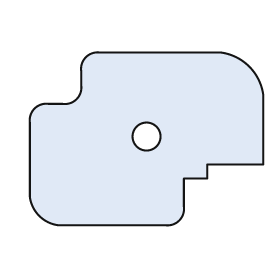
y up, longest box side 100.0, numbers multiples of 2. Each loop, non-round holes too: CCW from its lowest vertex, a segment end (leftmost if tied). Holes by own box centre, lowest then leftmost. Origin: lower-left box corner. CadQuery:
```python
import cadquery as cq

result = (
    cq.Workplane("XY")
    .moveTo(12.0, 0.0)
    .lineTo(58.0, 0.0)
    .threePointArc((64.0, 2.0), (66.0, 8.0))
    .lineTo(66.0, 20.0)
    .lineTo(76.0, 20.0)
    .lineTo(76.0, 26.0)
    .lineTo(100.0, 26.0)
    .lineTo(100.0, 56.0)
    .threePointArc((94.0, 68.0), (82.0, 74.0))
    .lineTo(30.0, 74.0)
    .threePointArc((24.0, 72.0), (22.0, 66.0))
    .lineTo(22.0, 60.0)
    .threePointArc((20.0, 54.0), (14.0, 52.0))
    .lineTo(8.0, 52.0)
    .threePointArc((2.0, 50.0), (0.0, 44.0))
    .lineTo(0.0, 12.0)
    .threePointArc((4.0, 4.0), (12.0, 0.0))
    .close()
    .moveTo(50.0, 38.0)
    .circle(6.0)
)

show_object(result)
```